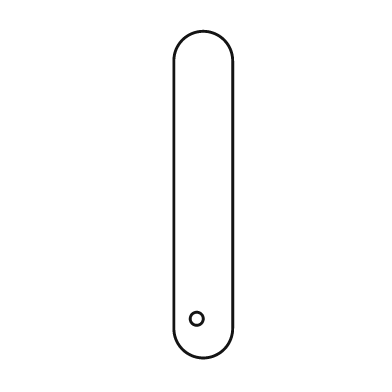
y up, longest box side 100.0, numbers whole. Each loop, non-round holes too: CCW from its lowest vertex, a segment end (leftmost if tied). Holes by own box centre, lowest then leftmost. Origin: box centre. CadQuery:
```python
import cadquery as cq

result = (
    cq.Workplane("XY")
    .moveTo(-9.0, -41.0)
    .threePointArc((0.0, -50.0), (9.0, -41.0))
    .lineTo(9.0, 41.0)
    .threePointArc((0.0, 50.0), (-9.0, 41.0))
    .close()
    .moveTo(-2.0, -38.0)
    .circle(2.0)
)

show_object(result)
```